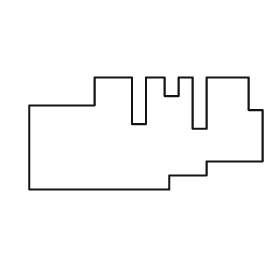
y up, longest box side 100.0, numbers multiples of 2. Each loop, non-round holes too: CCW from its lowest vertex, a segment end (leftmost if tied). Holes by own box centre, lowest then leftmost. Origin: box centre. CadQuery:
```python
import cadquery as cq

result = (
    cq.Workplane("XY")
    .moveTo(-50.0, -24.0)
    .lineTo(10.0, -24.0)
    .lineTo(10.0, -18.0)
    .lineTo(26.0, -18.0)
    .lineTo(26.0, -12.0)
    .lineTo(50.0, -12.0)
    .lineTo(50.0, 10.0)
    .lineTo(44.0, 10.0)
    .lineTo(44.0, 24.0)
    .lineTo(26.0, 24.0)
    .lineTo(26.0, 2.0)
    .lineTo(20.0, 2.0)
    .lineTo(20.0, 24.0)
    .lineTo(14.0, 24.0)
    .lineTo(14.0, 16.0)
    .lineTo(8.0, 16.0)
    .lineTo(8.0, 24.0)
    .lineTo(0.0, 24.0)
    .lineTo(0.0, 4.0)
    .lineTo(-6.0, 4.0)
    .lineTo(-6.0, 24.0)
    .lineTo(-22.0, 24.0)
    .lineTo(-22.0, 12.0)
    .lineTo(-50.0, 12.0)
    .close()
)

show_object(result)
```